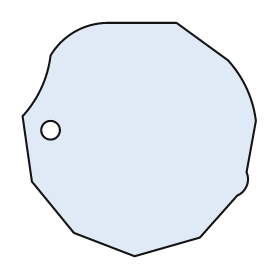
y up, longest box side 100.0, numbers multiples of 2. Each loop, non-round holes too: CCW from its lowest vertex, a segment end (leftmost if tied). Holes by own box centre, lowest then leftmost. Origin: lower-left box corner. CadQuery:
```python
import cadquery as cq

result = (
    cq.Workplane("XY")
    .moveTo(48.0, 0.0)
    .lineTo(76.0, 8.0)
    .lineTo(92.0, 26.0)
    .threePointArc((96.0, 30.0), (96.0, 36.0))
    .lineTo(100.0, 58.0)
    .threePointArc((96.0, 72.0), (88.0, 84.0))
    .lineTo(66.0, 100.0)
    .lineTo(36.0, 100.0)
    .threePointArc((22.0, 96.0), (12.0, 86.0))
    .threePointArc((8.0, 72.0), (0.0, 60.0))
    .lineTo(4.0, 32.0)
    .lineTo(22.0, 10.0)
    .close()
    .moveTo(12.0, 54.0)
    .circle(4.0)
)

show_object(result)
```